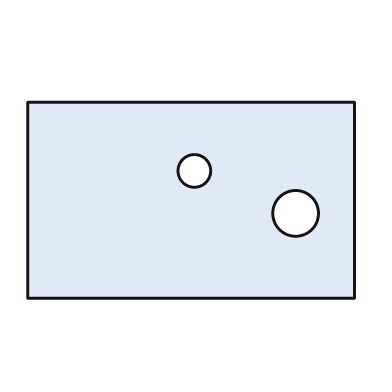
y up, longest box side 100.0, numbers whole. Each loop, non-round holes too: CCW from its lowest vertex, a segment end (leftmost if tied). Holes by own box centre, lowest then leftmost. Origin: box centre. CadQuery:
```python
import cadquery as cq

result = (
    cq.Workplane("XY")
    .moveTo(-50.0, -30.0)
    .lineTo(50.0, -30.0)
    .lineTo(50.0, 30.0)
    .lineTo(-50.0, 30.0)
    .close()
    .moveTo(32.0, -4.0)
    .circle(7.0)
    .moveTo(1.0, 9.0)
    .circle(5.0)
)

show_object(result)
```